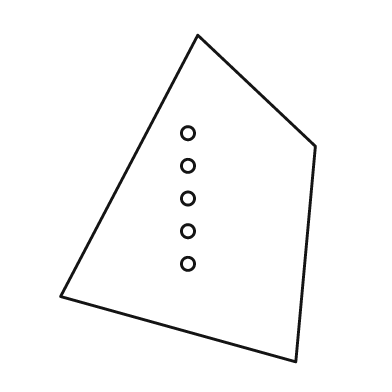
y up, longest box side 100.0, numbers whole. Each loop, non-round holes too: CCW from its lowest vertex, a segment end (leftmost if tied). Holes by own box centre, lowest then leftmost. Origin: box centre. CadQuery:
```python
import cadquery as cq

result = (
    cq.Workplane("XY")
    .moveTo(33.0, -50.0)
    .lineTo(39.0, 16.0)
    .lineTo(3.0, 50.0)
    .lineTo(-39.0, -30.0)
    .close()
    .moveTo(0.0, -20.0)
    .circle(2.0)
    .moveTo(0.0, -10.0)
    .circle(2.0)
    .moveTo(0.0, 0.0)
    .circle(2.0)
    .moveTo(0.0, 10.0)
    .circle(2.0)
    .moveTo(0.0, 20.0)
    .circle(2.0)
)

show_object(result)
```